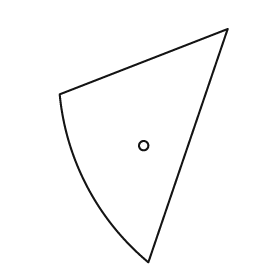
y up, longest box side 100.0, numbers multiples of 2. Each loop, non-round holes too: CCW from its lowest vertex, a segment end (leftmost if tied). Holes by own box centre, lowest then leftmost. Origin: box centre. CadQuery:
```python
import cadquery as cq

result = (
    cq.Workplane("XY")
    .moveTo(2.0, -50.0)
    .lineTo(36.0, 50.0)
    .lineTo(-36.0, 22.0)
    .threePointArc((-24.0, -18.0), (2.0, -50.0))
    .close()
    .moveTo(0.0, 0.0)
    .circle(2.0)
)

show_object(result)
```